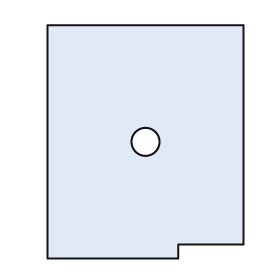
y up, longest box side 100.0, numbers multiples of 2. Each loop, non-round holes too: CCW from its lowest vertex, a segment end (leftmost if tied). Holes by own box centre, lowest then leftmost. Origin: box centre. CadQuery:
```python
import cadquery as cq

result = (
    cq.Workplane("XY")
    .moveTo(-42.0, -50.0)
    .lineTo(14.0, -50.0)
    .lineTo(14.0, -44.0)
    .lineTo(42.0, -44.0)
    .lineTo(42.0, 50.0)
    .lineTo(-42.0, 50.0)
    .close()
    .moveTo(0.0, 0.0)
    .circle(6.0)
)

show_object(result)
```